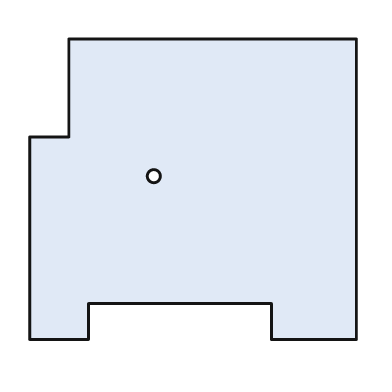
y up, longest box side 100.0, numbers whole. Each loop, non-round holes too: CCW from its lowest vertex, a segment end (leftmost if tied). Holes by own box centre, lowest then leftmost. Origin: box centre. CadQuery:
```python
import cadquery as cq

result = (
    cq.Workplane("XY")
    .moveTo(-50.0, -46.0)
    .lineTo(-32.0, -46.0)
    .lineTo(-32.0, -35.0)
    .lineTo(24.0, -35.0)
    .lineTo(24.0, -46.0)
    .lineTo(50.0, -46.0)
    .lineTo(50.0, 46.0)
    .lineTo(-38.0, 46.0)
    .lineTo(-38.0, 16.0)
    .lineTo(-50.0, 16.0)
    .close()
    .moveTo(-12.0, 4.0)
    .circle(2.0)
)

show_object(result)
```